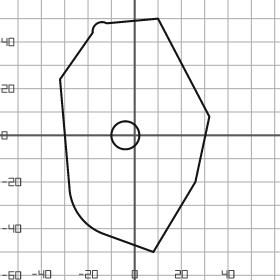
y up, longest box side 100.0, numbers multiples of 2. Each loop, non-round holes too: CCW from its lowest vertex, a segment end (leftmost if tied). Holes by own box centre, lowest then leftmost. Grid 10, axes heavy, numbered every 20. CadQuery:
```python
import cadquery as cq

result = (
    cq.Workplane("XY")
    .moveTo(8.0, -50.0)
    .lineTo(26.0, -20.0)
    .lineTo(32.0, 8.0)
    .lineTo(10.0, 50.0)
    .lineTo(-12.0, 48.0)
    .threePointArc((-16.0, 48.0), (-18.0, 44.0))
    .lineTo(-32.0, 24.0)
    .lineTo(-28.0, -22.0)
    .threePointArc((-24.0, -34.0), (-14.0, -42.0))
    .close()
    .moveTo(-4.0, 0.0)
    .circle(6.0)
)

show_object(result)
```